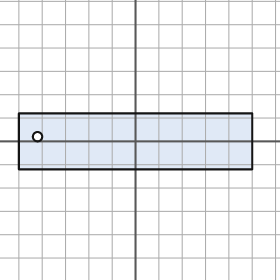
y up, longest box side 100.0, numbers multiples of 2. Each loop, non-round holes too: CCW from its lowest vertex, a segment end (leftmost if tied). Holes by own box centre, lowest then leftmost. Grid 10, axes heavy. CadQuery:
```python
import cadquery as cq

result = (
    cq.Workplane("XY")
    .moveTo(-50.0, -12.0)
    .lineTo(50.0, -12.0)
    .lineTo(50.0, 12.0)
    .lineTo(-50.0, 12.0)
    .close()
    .moveTo(-42.0, 2.0)
    .circle(2.0)
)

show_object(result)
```